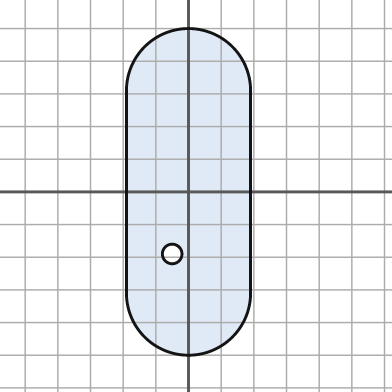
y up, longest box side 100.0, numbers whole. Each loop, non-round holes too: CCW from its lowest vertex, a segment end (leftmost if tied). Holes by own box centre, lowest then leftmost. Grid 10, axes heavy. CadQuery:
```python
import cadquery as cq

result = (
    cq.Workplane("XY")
    .moveTo(-19.0, -31.0)
    .threePointArc((0.0, -50.0), (19.0, -31.0))
    .lineTo(19.0, 31.0)
    .threePointArc((0.0, 50.0), (-19.0, 31.0))
    .close()
    .moveTo(-5.0, -19.0)
    .circle(3.0)
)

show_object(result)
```